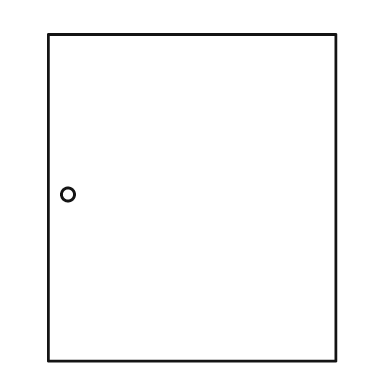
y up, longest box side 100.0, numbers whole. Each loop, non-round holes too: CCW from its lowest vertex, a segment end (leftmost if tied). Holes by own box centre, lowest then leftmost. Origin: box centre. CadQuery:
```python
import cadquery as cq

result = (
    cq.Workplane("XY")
    .moveTo(-44.0, -50.0)
    .lineTo(44.0, -50.0)
    .lineTo(44.0, 50.0)
    .lineTo(-44.0, 50.0)
    .close()
    .moveTo(-38.0, 1.0)
    .circle(2.0)
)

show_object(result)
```